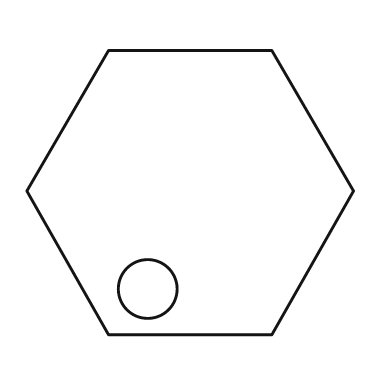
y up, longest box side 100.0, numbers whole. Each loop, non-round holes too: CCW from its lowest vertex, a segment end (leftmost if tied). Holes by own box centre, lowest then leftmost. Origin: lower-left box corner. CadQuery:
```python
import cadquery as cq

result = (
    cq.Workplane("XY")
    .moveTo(25.0, 0.0)
    .lineTo(75.0, 0.0)
    .lineTo(100.0, 44.0)
    .lineTo(75.0, 87.0)
    .lineTo(25.0, 87.0)
    .lineTo(0.0, 44.0)
    .close()
    .moveTo(37.0, 14.0)
    .circle(9.0)
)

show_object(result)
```